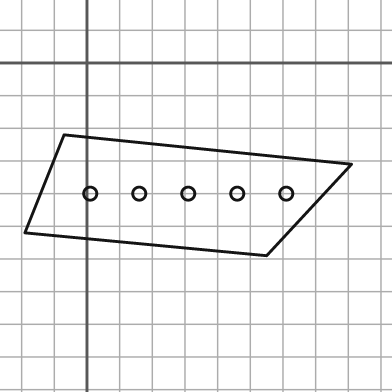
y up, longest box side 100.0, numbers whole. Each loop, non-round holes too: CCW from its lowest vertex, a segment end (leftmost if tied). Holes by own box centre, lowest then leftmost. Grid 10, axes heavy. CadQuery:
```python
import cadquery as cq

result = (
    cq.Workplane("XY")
    .moveTo(55.0, -59.0)
    .lineTo(81.0, -31.0)
    .lineTo(-7.0, -22.0)
    .lineTo(-19.0, -52.0)
    .close()
    .moveTo(1.0, -40.0)
    .circle(2.0)
    .moveTo(16.0, -40.0)
    .circle(2.0)
    .moveTo(31.0, -40.0)
    .circle(2.0)
    .moveTo(46.0, -40.0)
    .circle(2.0)
    .moveTo(61.0, -40.0)
    .circle(2.0)
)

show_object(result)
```